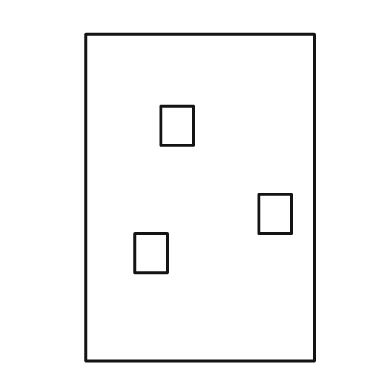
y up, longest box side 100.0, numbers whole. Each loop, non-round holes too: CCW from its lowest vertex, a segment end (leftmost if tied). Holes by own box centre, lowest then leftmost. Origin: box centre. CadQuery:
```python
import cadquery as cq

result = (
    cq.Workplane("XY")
    .moveTo(-35.0, -50.0)
    .lineTo(35.0, -50.0)
    .lineTo(35.0, 50.0)
    .lineTo(-35.0, 50.0)
    .close()
    .moveTo(-20.0, -23.0)
    .lineTo(-10.0, -23.0)
    .lineTo(-10.0, -11.0)
    .lineTo(-20.0, -11.0)
    .close()
    .moveTo(18.0, -11.0)
    .lineTo(28.0, -11.0)
    .lineTo(28.0, 1.0)
    .lineTo(18.0, 1.0)
    .close()
    .moveTo(-12.0, 16.0)
    .lineTo(-2.0, 16.0)
    .lineTo(-2.0, 28.0)
    .lineTo(-12.0, 28.0)
    .close()
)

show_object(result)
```